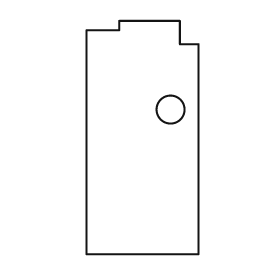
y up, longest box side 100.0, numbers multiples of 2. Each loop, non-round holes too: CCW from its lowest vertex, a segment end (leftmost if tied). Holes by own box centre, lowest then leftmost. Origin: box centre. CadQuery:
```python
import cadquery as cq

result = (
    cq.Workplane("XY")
    .moveTo(-24.0, -50.0)
    .lineTo(24.0, -50.0)
    .lineTo(24.0, 40.0)
    .lineTo(16.0, 40.0)
    .lineTo(16.0, 50.0)
    .lineTo(-10.0, 50.0)
    .lineTo(-10.0, 46.0)
    .lineTo(-24.0, 46.0)
    .close()
    .moveTo(12.0, 12.0)
    .circle(6.0)
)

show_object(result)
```